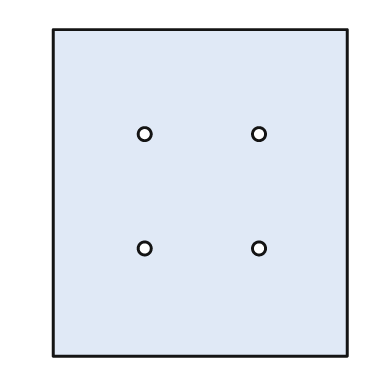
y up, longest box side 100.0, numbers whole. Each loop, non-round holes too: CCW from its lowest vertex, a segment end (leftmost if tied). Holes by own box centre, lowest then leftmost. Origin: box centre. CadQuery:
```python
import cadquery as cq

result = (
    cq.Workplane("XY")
    .moveTo(-45.0, -50.0)
    .lineTo(45.0, -50.0)
    .lineTo(45.0, 50.0)
    .lineTo(-45.0, 50.0)
    .close()
    .moveTo(-17.0, -17.0)
    .circle(2.0)
    .moveTo(18.0, -17.0)
    .circle(2.0)
    .moveTo(-17.0, 18.0)
    .circle(2.0)
    .moveTo(18.0, 18.0)
    .circle(2.0)
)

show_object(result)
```